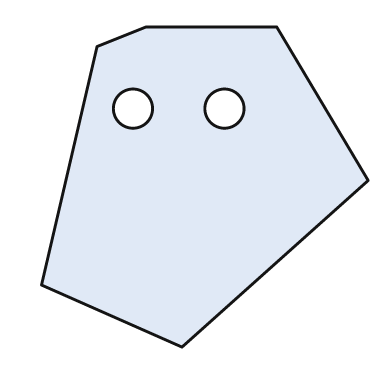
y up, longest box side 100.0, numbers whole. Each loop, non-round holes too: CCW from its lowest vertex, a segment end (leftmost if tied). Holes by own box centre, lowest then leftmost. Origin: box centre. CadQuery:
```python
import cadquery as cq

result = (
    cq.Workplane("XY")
    .moveTo(-7.0, -49.0)
    .lineTo(50.0, 2.0)
    .lineTo(22.0, 49.0)
    .lineTo(-18.0, 49.0)
    .lineTo(-33.0, 43.0)
    .lineTo(-50.0, -30.0)
    .close()
    .moveTo(-22.0, 24.0)
    .circle(6.0)
    .moveTo(6.0, 24.0)
    .circle(6.0)
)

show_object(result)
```